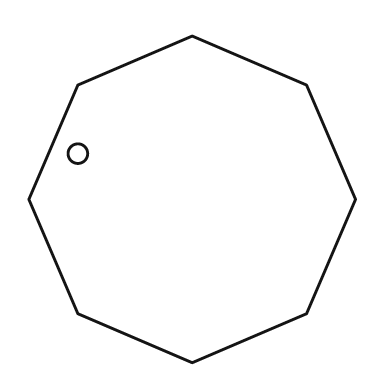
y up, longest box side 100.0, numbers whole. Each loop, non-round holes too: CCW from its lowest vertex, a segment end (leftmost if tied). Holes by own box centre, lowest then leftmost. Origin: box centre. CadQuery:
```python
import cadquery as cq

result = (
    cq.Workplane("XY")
    .moveTo(0.0, -50.0)
    .lineTo(35.0, -35.0)
    .lineTo(50.0, 0.0)
    .lineTo(35.0, 35.0)
    .lineTo(0.0, 50.0)
    .lineTo(-35.0, 35.0)
    .lineTo(-50.0, 0.0)
    .lineTo(-35.0, -35.0)
    .close()
    .moveTo(-35.0, 14.0)
    .circle(3.0)
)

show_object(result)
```